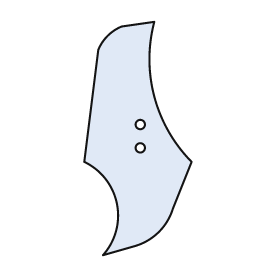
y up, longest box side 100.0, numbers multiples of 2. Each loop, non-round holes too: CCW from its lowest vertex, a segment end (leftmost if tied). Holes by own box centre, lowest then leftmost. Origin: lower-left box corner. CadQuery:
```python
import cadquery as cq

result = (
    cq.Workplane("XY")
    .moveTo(8.0, 0.0)
    .lineTo(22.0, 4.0)
    .threePointArc((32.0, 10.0), (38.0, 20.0))
    .lineTo(46.0, 40.0)
    .threePointArc((30.0, 68.0), (30.0, 100.0))
    .lineTo(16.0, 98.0)
    .threePointArc((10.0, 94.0), (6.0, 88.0))
    .lineTo(0.0, 40.0)
    .threePointArc((14.0, 22.0), (8.0, 0.0))
    .close()
    .moveTo(24.0, 46.0)
    .circle(2.0)
    .moveTo(24.0, 56.0)
    .circle(2.0)
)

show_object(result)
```